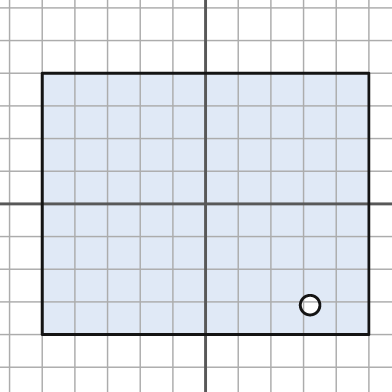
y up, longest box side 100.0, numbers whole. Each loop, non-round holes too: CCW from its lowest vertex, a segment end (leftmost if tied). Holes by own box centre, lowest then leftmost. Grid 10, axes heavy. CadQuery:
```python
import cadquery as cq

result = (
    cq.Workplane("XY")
    .moveTo(-50.0, -40.0)
    .lineTo(50.0, -40.0)
    .lineTo(50.0, 40.0)
    .lineTo(-50.0, 40.0)
    .close()
    .moveTo(32.0, -31.0)
    .circle(3.0)
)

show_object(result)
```